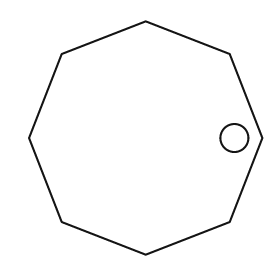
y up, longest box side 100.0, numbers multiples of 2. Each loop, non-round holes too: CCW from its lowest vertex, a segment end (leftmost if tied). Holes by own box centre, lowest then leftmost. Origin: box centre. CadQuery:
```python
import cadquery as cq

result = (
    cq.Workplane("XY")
    .moveTo(0.0, -50.0)
    .lineTo(36.0, -36.0)
    .lineTo(50.0, 0.0)
    .lineTo(36.0, 36.0)
    .lineTo(0.0, 50.0)
    .lineTo(-36.0, 36.0)
    .lineTo(-50.0, 0.0)
    .lineTo(-36.0, -36.0)
    .close()
    .moveTo(38.0, 0.0)
    .circle(6.0)
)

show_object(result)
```